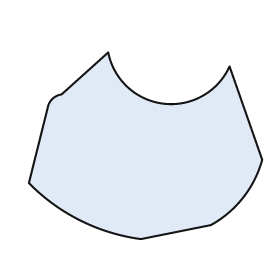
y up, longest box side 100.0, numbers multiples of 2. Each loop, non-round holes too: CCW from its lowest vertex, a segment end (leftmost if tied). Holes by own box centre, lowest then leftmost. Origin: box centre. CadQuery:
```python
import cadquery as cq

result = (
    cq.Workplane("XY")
    .moveTo(-2.0, -40.0)
    .lineTo(28.0, -34.0)
    .threePointArc((42.0, -22.0), (50.0, -6.0))
    .lineTo(36.0, 34.0)
    .threePointArc((8.0, 18.0), (-16.0, 40.0))
    .lineTo(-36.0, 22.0)
    .threePointArc((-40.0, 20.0), (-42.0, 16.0))
    .lineTo(-50.0, -16.0)
    .threePointArc((-28.0, -32.0), (-2.0, -40.0))
    .close()
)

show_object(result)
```